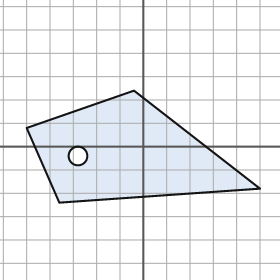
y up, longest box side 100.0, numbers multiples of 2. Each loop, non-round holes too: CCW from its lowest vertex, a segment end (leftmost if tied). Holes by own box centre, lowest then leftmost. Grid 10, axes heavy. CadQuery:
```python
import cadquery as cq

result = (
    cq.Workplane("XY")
    .moveTo(-36.0, -24.0)
    .lineTo(50.0, -18.0)
    .lineTo(-4.0, 24.0)
    .lineTo(-50.0, 8.0)
    .close()
    .moveTo(-28.0, -4.0)
    .circle(4.0)
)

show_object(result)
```